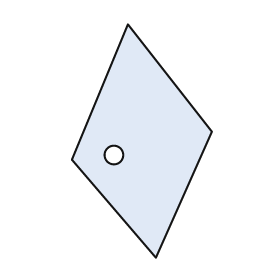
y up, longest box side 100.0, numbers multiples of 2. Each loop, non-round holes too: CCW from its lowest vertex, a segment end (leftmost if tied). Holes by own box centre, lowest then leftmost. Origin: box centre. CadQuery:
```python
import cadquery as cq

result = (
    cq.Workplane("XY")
    .moveTo(6.0, -50.0)
    .lineTo(30.0, 4.0)
    .lineTo(-6.0, 50.0)
    .lineTo(-30.0, -8.0)
    .close()
    .moveTo(-12.0, -6.0)
    .circle(4.0)
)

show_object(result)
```